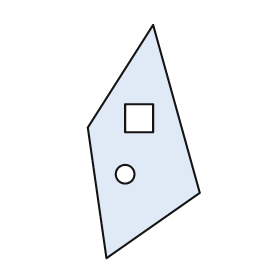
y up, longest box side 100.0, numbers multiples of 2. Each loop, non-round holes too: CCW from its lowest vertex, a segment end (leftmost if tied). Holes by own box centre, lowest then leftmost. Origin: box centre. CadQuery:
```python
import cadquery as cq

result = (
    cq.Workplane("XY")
    .moveTo(-16.0, -50.0)
    .lineTo(24.0, -22.0)
    .lineTo(4.0, 50.0)
    .lineTo(-24.0, 6.0)
    .close()
    .moveTo(-8.0, -14.0)
    .circle(4.0)
    .moveTo(-8.0, 4.0)
    .lineTo(4.0, 4.0)
    .lineTo(4.0, 16.0)
    .lineTo(-8.0, 16.0)
    .close()
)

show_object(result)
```